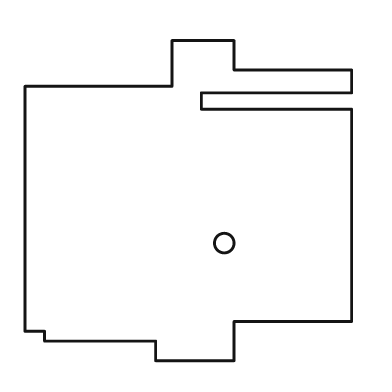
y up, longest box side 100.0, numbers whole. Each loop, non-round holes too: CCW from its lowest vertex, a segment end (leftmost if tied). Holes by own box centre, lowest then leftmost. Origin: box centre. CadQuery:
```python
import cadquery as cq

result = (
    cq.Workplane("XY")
    .moveTo(-10.0, -49.0)
    .lineTo(14.0, -49.0)
    .lineTo(14.0, -37.0)
    .lineTo(50.0, -37.0)
    .lineTo(50.0, 28.0)
    .lineTo(4.0, 28.0)
    .lineTo(4.0, 33.0)
    .lineTo(50.0, 33.0)
    .lineTo(50.0, 40.0)
    .lineTo(14.0, 40.0)
    .lineTo(14.0, 49.0)
    .lineTo(-5.0, 49.0)
    .lineTo(-5.0, 35.0)
    .lineTo(-50.0, 35.0)
    .lineTo(-50.0, -40.0)
    .lineTo(-44.0, -40.0)
    .lineTo(-44.0, -43.0)
    .lineTo(-10.0, -43.0)
    .close()
    .moveTo(11.0, -13.0)
    .circle(3.0)
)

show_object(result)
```